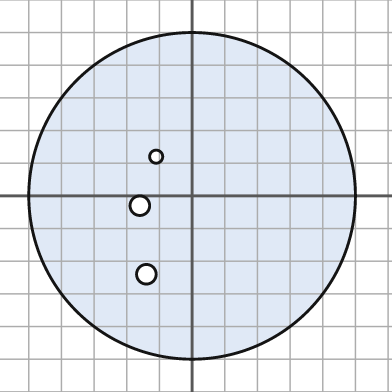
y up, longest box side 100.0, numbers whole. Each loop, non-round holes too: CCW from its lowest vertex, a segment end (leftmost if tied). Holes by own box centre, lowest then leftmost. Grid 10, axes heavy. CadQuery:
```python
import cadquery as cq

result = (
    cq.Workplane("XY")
    .moveTo(0.0, 0.0)
    .circle(50.0)
    .moveTo(-14.0, -24.0)
    .circle(3.0)
    .moveTo(-16.0, -3.0)
    .circle(3.0)
    .moveTo(-11.0, 12.0)
    .circle(2.0)
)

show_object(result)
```